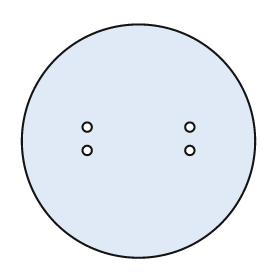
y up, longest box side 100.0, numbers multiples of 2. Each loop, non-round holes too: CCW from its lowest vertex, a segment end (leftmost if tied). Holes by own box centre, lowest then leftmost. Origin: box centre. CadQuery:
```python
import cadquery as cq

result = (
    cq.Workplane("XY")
    .moveTo(0.0, 0.0)
    .circle(50.0)
    .moveTo(-22.0, -4.0)
    .circle(2.0)
    .moveTo(22.0, -4.0)
    .circle(2.0)
    .moveTo(-22.0, 6.0)
    .circle(2.0)
    .moveTo(22.0, 6.0)
    .circle(2.0)
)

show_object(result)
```